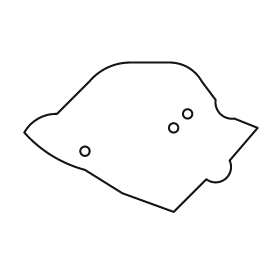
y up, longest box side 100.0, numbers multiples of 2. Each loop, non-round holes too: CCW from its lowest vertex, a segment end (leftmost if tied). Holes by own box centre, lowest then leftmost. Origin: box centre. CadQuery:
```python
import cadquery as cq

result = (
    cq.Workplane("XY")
    .moveTo(14.0, -32.0)
    .lineTo(28.0, -18.0)
    .threePointArc((36.0, -18.0), (38.0, -10.0))
    .lineTo(50.0, 4.0)
    .lineTo(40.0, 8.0)
    .threePointArc((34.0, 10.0), (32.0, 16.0))
    .lineTo(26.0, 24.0)
    .threePointArc((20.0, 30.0), (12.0, 32.0))
    .lineTo(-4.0, 32.0)
    .threePointArc((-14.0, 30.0), (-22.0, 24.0))
    .lineTo(-36.0, 10.0)
    .threePointArc((-44.0, 8.0), (-50.0, 2.0))
    .threePointArc((-38.0, -8.0), (-24.0, -14.0))
    .lineTo(-8.0, -24.0)
    .close()
    .moveTo(-24.0, -6.0)
    .circle(2.0)
    .moveTo(14.0, 4.0)
    .circle(2.0)
    .moveTo(20.0, 10.0)
    .circle(2.0)
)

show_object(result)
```